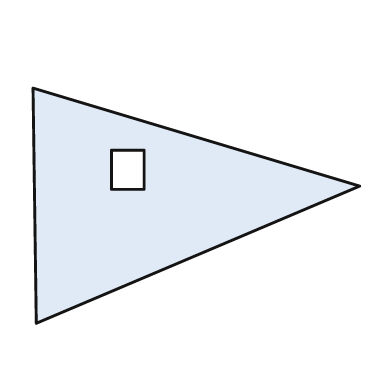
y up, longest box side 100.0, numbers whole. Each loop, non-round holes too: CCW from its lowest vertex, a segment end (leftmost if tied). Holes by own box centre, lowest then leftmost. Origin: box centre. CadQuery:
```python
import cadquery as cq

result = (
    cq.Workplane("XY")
    .moveTo(-49.0, -36.0)
    .lineTo(50.0, 6.0)
    .lineTo(-50.0, 36.0)
    .close()
    .moveTo(-26.0, 5.0)
    .lineTo(-16.0, 5.0)
    .lineTo(-16.0, 17.0)
    .lineTo(-26.0, 17.0)
    .close()
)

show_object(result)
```